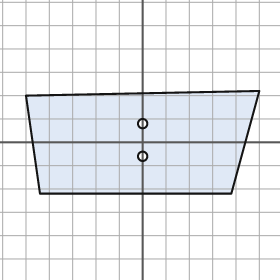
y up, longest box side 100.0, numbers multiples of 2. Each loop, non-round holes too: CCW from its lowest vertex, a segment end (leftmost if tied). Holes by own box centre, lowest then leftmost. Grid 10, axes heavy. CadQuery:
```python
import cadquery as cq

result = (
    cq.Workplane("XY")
    .moveTo(-44.0, -22.0)
    .lineTo(38.0, -22.0)
    .lineTo(50.0, 22.0)
    .lineTo(-50.0, 20.0)
    .close()
    .moveTo(0.0, -6.0)
    .circle(2.0)
    .moveTo(0.0, 8.0)
    .circle(2.0)
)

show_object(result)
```